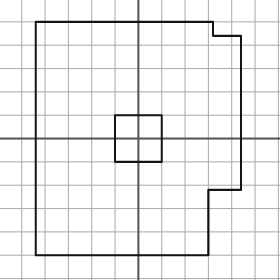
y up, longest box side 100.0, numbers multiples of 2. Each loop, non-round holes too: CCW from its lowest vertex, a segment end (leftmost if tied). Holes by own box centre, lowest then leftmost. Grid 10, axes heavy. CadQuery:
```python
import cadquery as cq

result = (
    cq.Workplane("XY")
    .moveTo(-44.0, -50.0)
    .lineTo(30.0, -50.0)
    .lineTo(30.0, -22.0)
    .lineTo(44.0, -22.0)
    .lineTo(44.0, 44.0)
    .lineTo(32.0, 44.0)
    .lineTo(32.0, 50.0)
    .lineTo(-44.0, 50.0)
    .close()
    .moveTo(-10.0, -10.0)
    .lineTo(10.0, -10.0)
    .lineTo(10.0, 10.0)
    .lineTo(-10.0, 10.0)
    .close()
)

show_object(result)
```